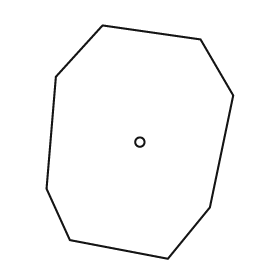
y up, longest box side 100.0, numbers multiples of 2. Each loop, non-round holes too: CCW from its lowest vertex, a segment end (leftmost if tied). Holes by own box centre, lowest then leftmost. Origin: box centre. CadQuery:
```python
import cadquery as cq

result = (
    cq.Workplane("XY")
    .moveTo(12.0, -50.0)
    .lineTo(30.0, -28.0)
    .lineTo(40.0, 20.0)
    .lineTo(26.0, 44.0)
    .lineTo(-16.0, 50.0)
    .lineTo(-36.0, 28.0)
    .lineTo(-40.0, -20.0)
    .lineTo(-30.0, -42.0)
    .close()
    .moveTo(0.0, 0.0)
    .circle(2.0)
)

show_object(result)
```